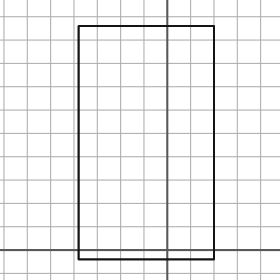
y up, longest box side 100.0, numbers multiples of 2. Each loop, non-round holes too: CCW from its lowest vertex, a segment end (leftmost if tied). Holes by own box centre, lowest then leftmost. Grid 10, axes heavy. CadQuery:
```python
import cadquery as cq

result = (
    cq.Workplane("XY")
    .moveTo(-38.0, -4.0)
    .lineTo(20.0, -4.0)
    .lineTo(20.0, 96.0)
    .lineTo(-38.0, 96.0)
    .close()
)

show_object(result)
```